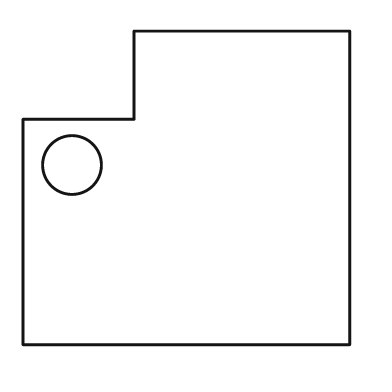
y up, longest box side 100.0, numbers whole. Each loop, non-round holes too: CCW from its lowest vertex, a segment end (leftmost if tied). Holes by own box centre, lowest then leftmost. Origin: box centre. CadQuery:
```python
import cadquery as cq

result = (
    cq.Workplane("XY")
    .moveTo(-50.0, -48.0)
    .lineTo(50.0, -48.0)
    .lineTo(50.0, 48.0)
    .lineTo(-16.0, 48.0)
    .lineTo(-16.0, 21.0)
    .lineTo(-50.0, 21.0)
    .close()
    .moveTo(-35.0, 7.0)
    .circle(9.0)
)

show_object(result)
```